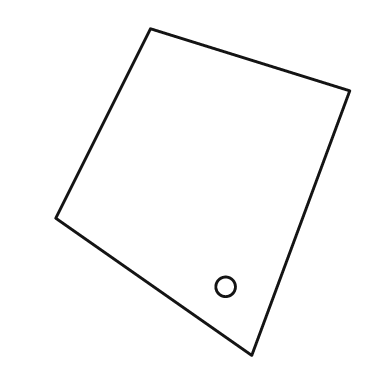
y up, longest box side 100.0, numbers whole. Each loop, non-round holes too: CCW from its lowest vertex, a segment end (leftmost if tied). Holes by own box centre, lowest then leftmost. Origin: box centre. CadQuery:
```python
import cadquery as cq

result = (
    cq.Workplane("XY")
    .moveTo(15.0, -50.0)
    .lineTo(45.0, 31.0)
    .lineTo(-16.0, 50.0)
    .lineTo(-45.0, -8.0)
    .close()
    .moveTo(7.0, -29.0)
    .circle(3.0)
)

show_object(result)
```